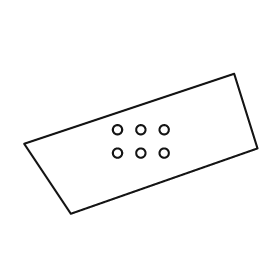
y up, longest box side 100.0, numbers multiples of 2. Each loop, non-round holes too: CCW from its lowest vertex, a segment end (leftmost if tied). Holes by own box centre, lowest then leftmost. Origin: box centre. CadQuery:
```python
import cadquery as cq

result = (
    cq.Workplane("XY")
    .moveTo(-30.0, -30.0)
    .lineTo(50.0, -2.0)
    .lineTo(40.0, 30.0)
    .lineTo(-50.0, 0.0)
    .close()
    .moveTo(-10.0, -4.0)
    .circle(2.0)
    .moveTo(0.0, -4.0)
    .circle(2.0)
    .moveTo(10.0, -4.0)
    .circle(2.0)
    .moveTo(-10.0, 6.0)
    .circle(2.0)
    .moveTo(0.0, 6.0)
    .circle(2.0)
    .moveTo(10.0, 6.0)
    .circle(2.0)
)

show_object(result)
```